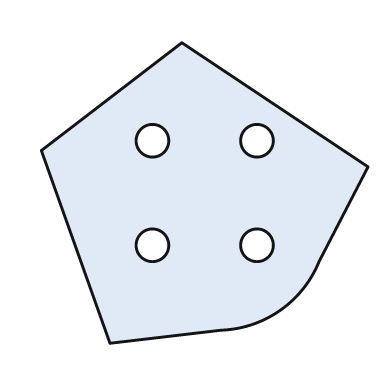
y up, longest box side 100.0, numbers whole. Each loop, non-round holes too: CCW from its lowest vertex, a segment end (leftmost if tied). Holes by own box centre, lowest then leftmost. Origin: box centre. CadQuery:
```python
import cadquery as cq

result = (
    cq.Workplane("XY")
    .moveTo(-29.0, -46.0)
    .lineTo(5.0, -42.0)
    .threePointArc((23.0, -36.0), (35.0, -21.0))
    .lineTo(50.0, 8.0)
    .lineTo(-7.0, 46.0)
    .lineTo(-50.0, 13.0)
    .close()
    .moveTo(-16.0, -16.0)
    .circle(5.0)
    .moveTo(16.0, -16.0)
    .circle(5.0)
    .moveTo(-16.0, 16.0)
    .circle(5.0)
    .moveTo(16.0, 16.0)
    .circle(5.0)
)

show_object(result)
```